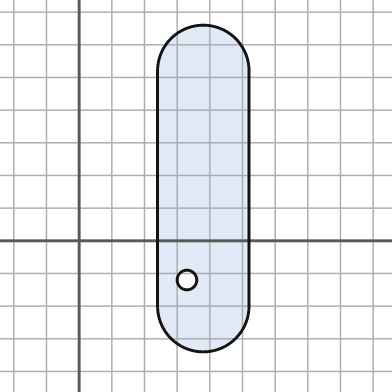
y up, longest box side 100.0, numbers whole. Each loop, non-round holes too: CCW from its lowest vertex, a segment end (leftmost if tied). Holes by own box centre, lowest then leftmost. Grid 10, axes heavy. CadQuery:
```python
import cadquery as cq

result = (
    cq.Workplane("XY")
    .moveTo(24.0, -20.0)
    .threePointArc((38.0, -34.0), (52.0, -20.0))
    .lineTo(52.0, 52.0)
    .threePointArc((38.0, 66.0), (24.0, 52.0))
    .close()
    .moveTo(33.0, -12.0)
    .circle(3.0)
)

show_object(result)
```